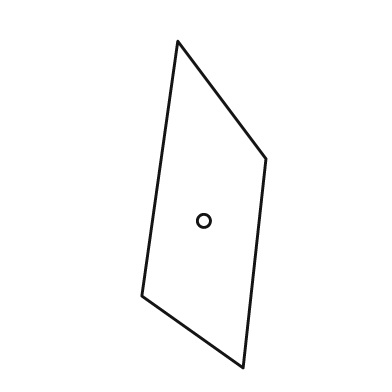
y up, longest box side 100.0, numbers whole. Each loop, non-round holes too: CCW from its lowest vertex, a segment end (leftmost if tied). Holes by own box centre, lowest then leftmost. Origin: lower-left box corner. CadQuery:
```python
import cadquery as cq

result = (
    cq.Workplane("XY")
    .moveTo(31.0, 0.0)
    .lineTo(38.0, 64.0)
    .lineTo(11.0, 100.0)
    .lineTo(0.0, 22.0)
    .close()
    .moveTo(19.0, 45.0)
    .circle(2.0)
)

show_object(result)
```